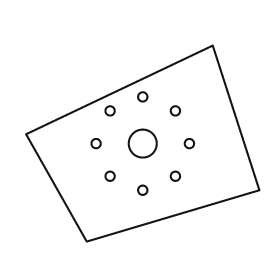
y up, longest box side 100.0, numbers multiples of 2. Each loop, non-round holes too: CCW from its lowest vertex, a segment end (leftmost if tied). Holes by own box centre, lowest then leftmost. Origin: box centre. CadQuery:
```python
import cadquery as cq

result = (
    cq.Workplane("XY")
    .moveTo(-24.0, -42.0)
    .lineTo(50.0, -20.0)
    .lineTo(30.0, 42.0)
    .lineTo(-50.0, 4.0)
    .close()
    .moveTo(0.0, -20.0)
    .circle(2.0)
    .moveTo(-14.0, -14.0)
    .circle(2.0)
    .moveTo(14.0, -14.0)
    .circle(2.0)
    .moveTo(-20.0, 0.0)
    .circle(2.0)
    .moveTo(0.0, 0.0)
    .circle(6.0)
    .moveTo(20.0, 0.0)
    .circle(2.0)
    .moveTo(-14.0, 14.0)
    .circle(2.0)
    .moveTo(14.0, 14.0)
    .circle(2.0)
    .moveTo(0.0, 20.0)
    .circle(2.0)
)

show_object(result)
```